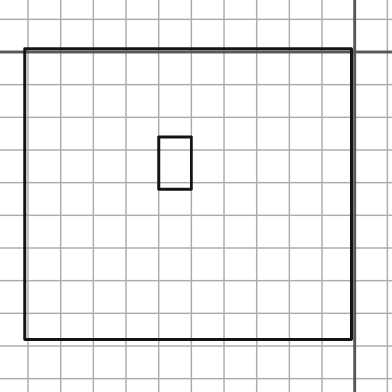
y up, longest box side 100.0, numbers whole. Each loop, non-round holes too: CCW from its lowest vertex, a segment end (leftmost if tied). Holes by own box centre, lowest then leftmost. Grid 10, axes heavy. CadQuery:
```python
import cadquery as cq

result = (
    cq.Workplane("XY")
    .moveTo(-101.0, -88.0)
    .lineTo(-1.0, -88.0)
    .lineTo(-1.0, 1.0)
    .lineTo(-101.0, 1.0)
    .close()
    .moveTo(-60.0, -42.0)
    .lineTo(-50.0, -42.0)
    .lineTo(-50.0, -26.0)
    .lineTo(-60.0, -26.0)
    .close()
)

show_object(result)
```